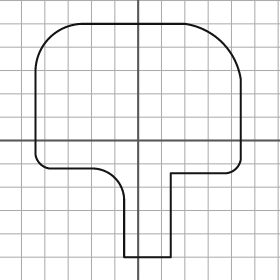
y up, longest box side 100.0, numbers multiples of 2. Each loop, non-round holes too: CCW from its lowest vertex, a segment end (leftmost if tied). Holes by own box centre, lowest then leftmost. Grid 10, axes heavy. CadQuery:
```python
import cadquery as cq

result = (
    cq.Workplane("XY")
    .moveTo(-6.0, -50.0)
    .lineTo(14.0, -50.0)
    .lineTo(14.0, -14.0)
    .lineTo(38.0, -14.0)
    .threePointArc((42.0, -12.0), (44.0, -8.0))
    .lineTo(44.0, 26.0)
    .threePointArc((36.0, 42.0), (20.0, 50.0))
    .lineTo(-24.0, 50.0)
    .threePointArc((-38.0, 44.0), (-44.0, 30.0))
    .lineTo(-44.0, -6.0)
    .threePointArc((-42.0, -10.0), (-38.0, -12.0))
    .lineTo(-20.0, -12.0)
    .threePointArc((-10.0, -16.0), (-6.0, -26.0))
    .close()
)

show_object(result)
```